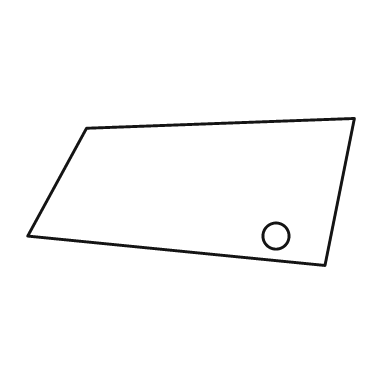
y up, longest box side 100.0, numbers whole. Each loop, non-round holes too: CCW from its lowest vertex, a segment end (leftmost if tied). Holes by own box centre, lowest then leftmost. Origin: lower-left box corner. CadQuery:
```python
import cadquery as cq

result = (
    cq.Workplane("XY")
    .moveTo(91.0, 0.0)
    .lineTo(100.0, 45.0)
    .lineTo(18.0, 42.0)
    .lineTo(0.0, 9.0)
    .close()
    .moveTo(76.0, 9.0)
    .circle(4.0)
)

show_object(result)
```